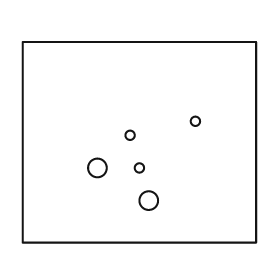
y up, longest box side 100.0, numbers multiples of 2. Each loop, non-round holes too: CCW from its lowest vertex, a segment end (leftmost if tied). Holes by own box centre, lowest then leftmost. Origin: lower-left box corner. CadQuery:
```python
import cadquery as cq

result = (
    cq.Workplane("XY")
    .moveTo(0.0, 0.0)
    .lineTo(100.0, 0.0)
    .lineTo(100.0, 86.0)
    .lineTo(0.0, 86.0)
    .close()
    .moveTo(54.0, 18.0)
    .circle(4.0)
    .moveTo(32.0, 32.0)
    .circle(4.0)
    .moveTo(50.0, 32.0)
    .circle(2.0)
    .moveTo(46.0, 46.0)
    .circle(2.0)
    .moveTo(74.0, 52.0)
    .circle(2.0)
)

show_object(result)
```